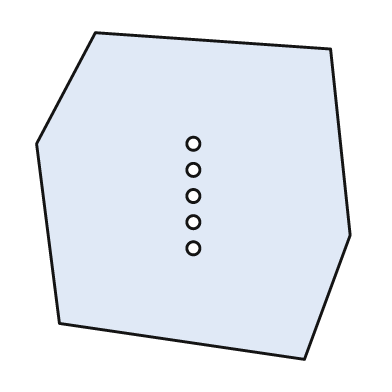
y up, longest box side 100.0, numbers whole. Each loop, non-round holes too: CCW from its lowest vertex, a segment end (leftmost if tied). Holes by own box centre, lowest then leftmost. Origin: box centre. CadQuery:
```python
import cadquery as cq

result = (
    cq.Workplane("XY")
    .moveTo(34.0, -50.0)
    .lineTo(48.0, -12.0)
    .lineTo(42.0, 45.0)
    .lineTo(-30.0, 50.0)
    .lineTo(-48.0, 16.0)
    .lineTo(-41.0, -39.0)
    .close()
    .moveTo(0.0, -16.0)
    .circle(2.0)
    .moveTo(0.0, -8.0)
    .circle(2.0)
    .moveTo(0.0, 0.0)
    .circle(2.0)
    .moveTo(0.0, 8.0)
    .circle(2.0)
    .moveTo(0.0, 16.0)
    .circle(2.0)
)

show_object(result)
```